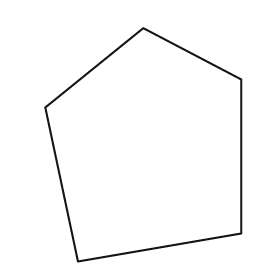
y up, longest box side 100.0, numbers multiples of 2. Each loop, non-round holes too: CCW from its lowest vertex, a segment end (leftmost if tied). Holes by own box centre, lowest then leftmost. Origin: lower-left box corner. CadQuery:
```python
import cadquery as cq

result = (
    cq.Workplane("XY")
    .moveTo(14.0, 0.0)
    .lineTo(84.0, 12.0)
    .lineTo(84.0, 78.0)
    .lineTo(42.0, 100.0)
    .lineTo(0.0, 66.0)
    .close()
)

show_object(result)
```